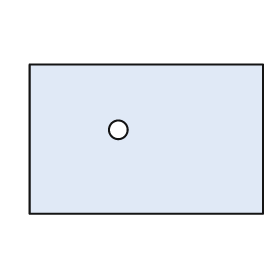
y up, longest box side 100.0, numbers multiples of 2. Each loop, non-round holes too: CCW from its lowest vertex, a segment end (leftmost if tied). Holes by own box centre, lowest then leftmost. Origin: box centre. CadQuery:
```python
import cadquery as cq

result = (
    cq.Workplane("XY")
    .moveTo(-50.0, -32.0)
    .lineTo(50.0, -32.0)
    .lineTo(50.0, 32.0)
    .lineTo(-50.0, 32.0)
    .close()
    .moveTo(-12.0, 4.0)
    .circle(4.0)
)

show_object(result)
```